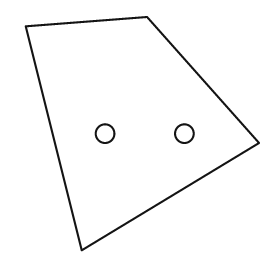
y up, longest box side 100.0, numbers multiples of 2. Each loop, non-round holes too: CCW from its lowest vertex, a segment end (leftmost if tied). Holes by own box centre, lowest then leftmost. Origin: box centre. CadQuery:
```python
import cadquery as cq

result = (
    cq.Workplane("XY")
    .moveTo(-26.0, -50.0)
    .lineTo(50.0, -4.0)
    .lineTo(2.0, 50.0)
    .lineTo(-50.0, 46.0)
    .close()
    .moveTo(-16.0, 0.0)
    .circle(4.0)
    .moveTo(18.0, 0.0)
    .circle(4.0)
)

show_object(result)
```